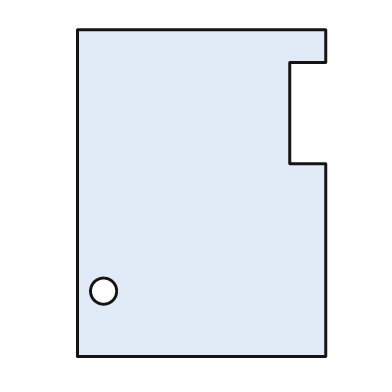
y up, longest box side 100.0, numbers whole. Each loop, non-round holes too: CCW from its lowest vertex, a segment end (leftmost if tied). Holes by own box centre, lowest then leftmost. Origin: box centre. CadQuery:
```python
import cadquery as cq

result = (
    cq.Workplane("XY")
    .moveTo(-38.0, -50.0)
    .lineTo(38.0, -50.0)
    .lineTo(38.0, 9.0)
    .lineTo(27.0, 9.0)
    .lineTo(27.0, 40.0)
    .lineTo(38.0, 40.0)
    .lineTo(38.0, 50.0)
    .lineTo(-38.0, 50.0)
    .close()
    .moveTo(-30.0, -30.0)
    .circle(4.0)
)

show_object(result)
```